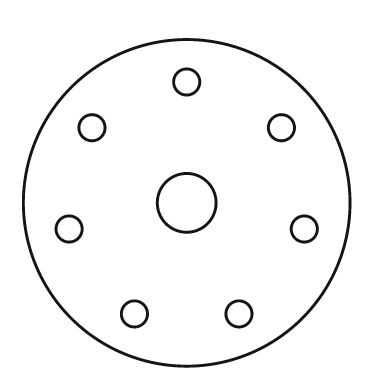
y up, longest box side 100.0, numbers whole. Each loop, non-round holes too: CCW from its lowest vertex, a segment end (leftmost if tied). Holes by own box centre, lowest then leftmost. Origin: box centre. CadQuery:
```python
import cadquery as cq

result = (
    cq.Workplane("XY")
    .moveTo(0.0, 0.0)
    .circle(50.0)
    .moveTo(-16.0, -34.0)
    .circle(4.0)
    .moveTo(16.0, -34.0)
    .circle(4.0)
    .moveTo(-36.0, -8.0)
    .circle(4.0)
    .moveTo(36.0, -8.0)
    .circle(4.0)
    .moveTo(0.0, 0.0)
    .circle(9.0)
    .moveTo(-29.0, 23.0)
    .circle(4.0)
    .moveTo(29.0, 23.0)
    .circle(4.0)
    .moveTo(0.0, 37.0)
    .circle(4.0)
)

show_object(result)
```